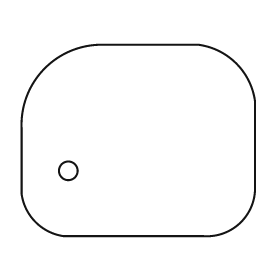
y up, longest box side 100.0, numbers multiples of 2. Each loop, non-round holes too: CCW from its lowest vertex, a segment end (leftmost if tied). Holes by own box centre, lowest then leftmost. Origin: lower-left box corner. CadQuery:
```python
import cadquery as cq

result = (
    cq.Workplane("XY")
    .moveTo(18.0, 0.0)
    .lineTo(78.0, 0.0)
    .threePointArc((94.0, 6.0), (100.0, 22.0))
    .lineTo(100.0, 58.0)
    .threePointArc((92.0, 74.0), (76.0, 82.0))
    .lineTo(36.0, 82.0)
    .threePointArc((10.0, 72.0), (0.0, 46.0))
    .lineTo(0.0, 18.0)
    .threePointArc((6.0, 6.0), (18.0, 0.0))
    .close()
    .moveTo(20.0, 28.0)
    .circle(4.0)
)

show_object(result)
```